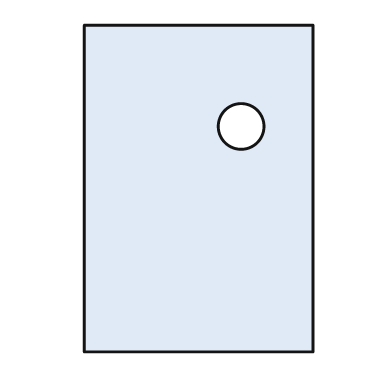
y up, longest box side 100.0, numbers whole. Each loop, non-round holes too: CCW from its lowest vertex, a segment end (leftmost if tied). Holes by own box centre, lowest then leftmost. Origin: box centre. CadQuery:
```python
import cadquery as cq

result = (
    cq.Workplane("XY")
    .moveTo(-35.0, -50.0)
    .lineTo(35.0, -50.0)
    .lineTo(35.0, 50.0)
    .lineTo(-35.0, 50.0)
    .close()
    .moveTo(13.0, 19.0)
    .circle(7.0)
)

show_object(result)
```